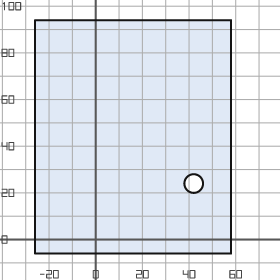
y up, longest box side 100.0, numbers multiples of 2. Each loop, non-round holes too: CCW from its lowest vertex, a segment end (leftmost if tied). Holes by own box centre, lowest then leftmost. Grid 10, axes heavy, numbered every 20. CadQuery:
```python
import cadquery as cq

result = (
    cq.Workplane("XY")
    .moveTo(-26.0, -6.0)
    .lineTo(58.0, -6.0)
    .lineTo(58.0, 94.0)
    .lineTo(-26.0, 94.0)
    .close()
    .moveTo(42.0, 24.0)
    .circle(4.0)
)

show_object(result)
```